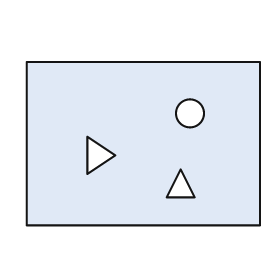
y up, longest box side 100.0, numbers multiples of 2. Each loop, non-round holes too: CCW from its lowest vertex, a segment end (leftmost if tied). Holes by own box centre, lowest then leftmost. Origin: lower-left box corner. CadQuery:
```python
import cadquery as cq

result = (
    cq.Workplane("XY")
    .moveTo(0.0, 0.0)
    .lineTo(100.0, 0.0)
    .lineTo(100.0, 70.0)
    .lineTo(0.0, 70.0)
    .close()
    .moveTo(60.0, 12.0)
    .lineTo(72.0, 12.0)
    .lineTo(66.0, 24.0)
    .close()
    .moveTo(26.0, 22.0)
    .lineTo(38.0, 30.0)
    .lineTo(26.0, 38.0)
    .close()
    .moveTo(70.0, 48.0)
    .circle(6.0)
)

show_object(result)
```